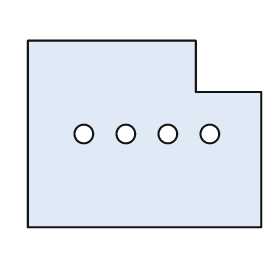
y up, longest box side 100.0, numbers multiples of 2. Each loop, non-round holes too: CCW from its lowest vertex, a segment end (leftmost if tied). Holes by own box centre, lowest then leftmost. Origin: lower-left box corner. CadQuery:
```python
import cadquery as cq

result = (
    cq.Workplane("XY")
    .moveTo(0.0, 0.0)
    .lineTo(100.0, 0.0)
    .lineTo(100.0, 58.0)
    .lineTo(72.0, 58.0)
    .lineTo(72.0, 80.0)
    .lineTo(0.0, 80.0)
    .close()
    .moveTo(24.0, 40.0)
    .circle(4.0)
    .moveTo(42.0, 40.0)
    .circle(4.0)
    .moveTo(60.0, 40.0)
    .circle(4.0)
    .moveTo(78.0, 40.0)
    .circle(4.0)
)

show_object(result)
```